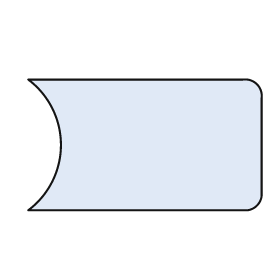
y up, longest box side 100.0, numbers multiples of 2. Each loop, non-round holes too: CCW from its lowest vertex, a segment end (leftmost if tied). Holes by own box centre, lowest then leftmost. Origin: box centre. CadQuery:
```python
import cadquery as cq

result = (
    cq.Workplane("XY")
    .moveTo(-50.0, -28.0)
    .lineTo(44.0, -28.0)
    .threePointArc((48.0, -26.0), (50.0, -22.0))
    .lineTo(50.0, 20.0)
    .threePointArc((48.0, 26.0), (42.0, 28.0))
    .lineTo(-50.0, 28.0)
    .threePointArc((-36.0, 0.0), (-50.0, -28.0))
    .close()
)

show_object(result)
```